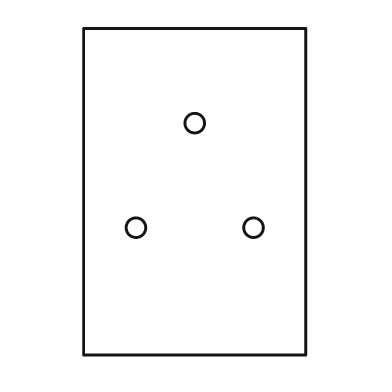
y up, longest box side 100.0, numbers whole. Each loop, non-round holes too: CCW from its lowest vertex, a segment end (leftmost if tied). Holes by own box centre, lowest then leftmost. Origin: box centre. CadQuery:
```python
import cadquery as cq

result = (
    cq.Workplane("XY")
    .moveTo(-34.0, -50.0)
    .lineTo(34.0, -50.0)
    .lineTo(34.0, 50.0)
    .lineTo(-34.0, 50.0)
    .close()
    .moveTo(-18.0, -11.0)
    .circle(3.0)
    .moveTo(18.0, -11.0)
    .circle(3.0)
    .moveTo(0.0, 21.0)
    .circle(3.0)
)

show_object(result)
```